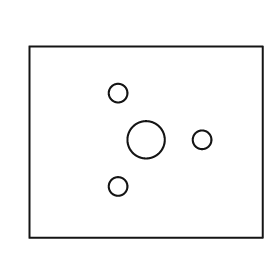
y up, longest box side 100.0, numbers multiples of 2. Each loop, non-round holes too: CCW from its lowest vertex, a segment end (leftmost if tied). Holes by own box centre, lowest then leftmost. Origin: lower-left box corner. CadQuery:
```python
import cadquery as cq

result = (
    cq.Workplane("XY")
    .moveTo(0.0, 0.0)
    .lineTo(100.0, 0.0)
    .lineTo(100.0, 82.0)
    .lineTo(0.0, 82.0)
    .close()
    .moveTo(38.0, 22.0)
    .circle(4.0)
    .moveTo(50.0, 42.0)
    .circle(8.0)
    .moveTo(74.0, 42.0)
    .circle(4.0)
    .moveTo(38.0, 62.0)
    .circle(4.0)
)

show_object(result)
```